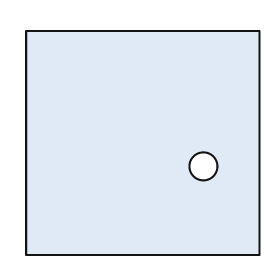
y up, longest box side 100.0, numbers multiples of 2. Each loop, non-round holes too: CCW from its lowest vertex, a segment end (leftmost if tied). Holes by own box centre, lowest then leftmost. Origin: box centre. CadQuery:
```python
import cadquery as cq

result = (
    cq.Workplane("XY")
    .moveTo(-50.0, -48.0)
    .lineTo(50.0, -48.0)
    .lineTo(50.0, 48.0)
    .lineTo(-50.0, 48.0)
    .close()
    .moveTo(26.0, -10.0)
    .circle(6.0)
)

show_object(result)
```